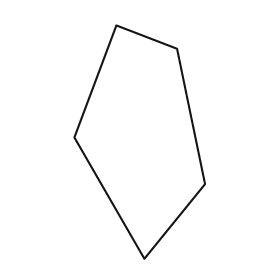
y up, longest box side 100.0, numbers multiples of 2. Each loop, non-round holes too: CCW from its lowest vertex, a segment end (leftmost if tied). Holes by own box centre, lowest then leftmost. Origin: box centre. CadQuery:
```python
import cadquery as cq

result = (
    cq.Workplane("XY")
    .moveTo(2.0, -50.0)
    .lineTo(28.0, -18.0)
    .lineTo(16.0, 40.0)
    .lineTo(-10.0, 50.0)
    .lineTo(-28.0, 2.0)
    .close()
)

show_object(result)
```